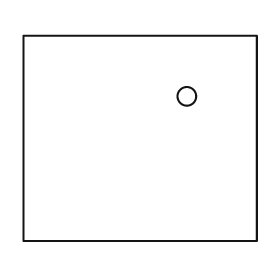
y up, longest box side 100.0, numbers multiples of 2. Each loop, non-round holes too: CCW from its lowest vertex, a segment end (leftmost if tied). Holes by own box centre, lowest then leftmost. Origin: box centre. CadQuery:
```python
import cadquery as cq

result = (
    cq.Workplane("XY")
    .moveTo(-50.0, -44.0)
    .lineTo(50.0, -44.0)
    .lineTo(50.0, 44.0)
    .lineTo(-50.0, 44.0)
    .close()
    .moveTo(20.0, 18.0)
    .circle(4.0)
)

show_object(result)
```